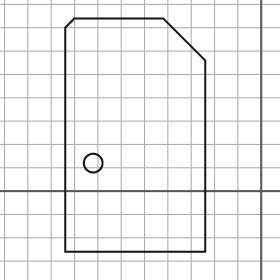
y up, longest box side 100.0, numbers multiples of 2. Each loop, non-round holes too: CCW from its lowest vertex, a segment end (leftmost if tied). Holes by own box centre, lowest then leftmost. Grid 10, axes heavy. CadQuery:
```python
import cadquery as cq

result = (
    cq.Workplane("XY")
    .moveTo(-84.0, -26.0)
    .lineTo(-24.0, -26.0)
    .lineTo(-24.0, 56.0)
    .lineTo(-42.0, 74.0)
    .lineTo(-80.0, 74.0)
    .lineTo(-84.0, 70.0)
    .close()
    .moveTo(-72.0, 12.0)
    .circle(4.0)
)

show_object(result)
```